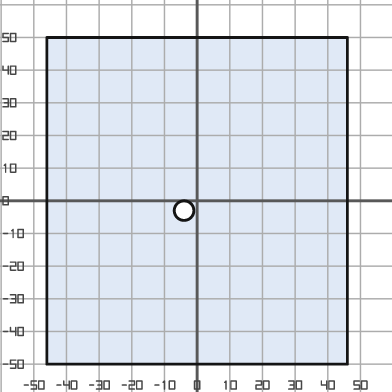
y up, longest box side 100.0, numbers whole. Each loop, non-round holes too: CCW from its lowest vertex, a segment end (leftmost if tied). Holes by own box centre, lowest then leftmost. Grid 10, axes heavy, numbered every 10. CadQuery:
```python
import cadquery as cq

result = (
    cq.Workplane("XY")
    .moveTo(-46.0, -50.0)
    .lineTo(46.0, -50.0)
    .lineTo(46.0, 50.0)
    .lineTo(-46.0, 50.0)
    .close()
    .moveTo(-4.0, -3.0)
    .circle(3.0)
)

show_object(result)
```